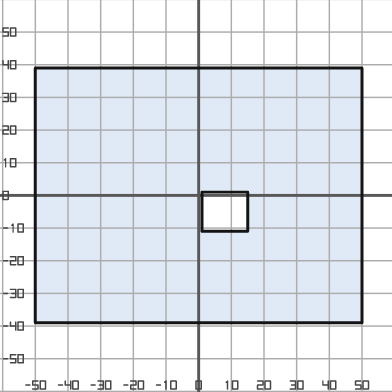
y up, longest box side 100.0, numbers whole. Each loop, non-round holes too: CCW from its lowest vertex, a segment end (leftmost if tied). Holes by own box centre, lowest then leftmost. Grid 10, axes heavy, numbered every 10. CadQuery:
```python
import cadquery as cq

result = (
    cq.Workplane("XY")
    .moveTo(-50.0, -39.0)
    .lineTo(50.0, -39.0)
    .lineTo(50.0, 39.0)
    .lineTo(-50.0, 39.0)
    .close()
    .moveTo(1.0, -11.0)
    .lineTo(15.0, -11.0)
    .lineTo(15.0, 1.0)
    .lineTo(1.0, 1.0)
    .close()
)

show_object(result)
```